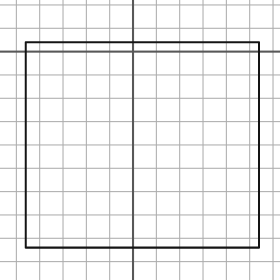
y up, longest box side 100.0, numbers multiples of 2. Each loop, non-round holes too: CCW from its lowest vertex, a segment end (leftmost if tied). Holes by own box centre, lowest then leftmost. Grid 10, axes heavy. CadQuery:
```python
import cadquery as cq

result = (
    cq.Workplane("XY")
    .moveTo(-46.0, -84.0)
    .lineTo(54.0, -84.0)
    .lineTo(54.0, 4.0)
    .lineTo(-46.0, 4.0)
    .close()
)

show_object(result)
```